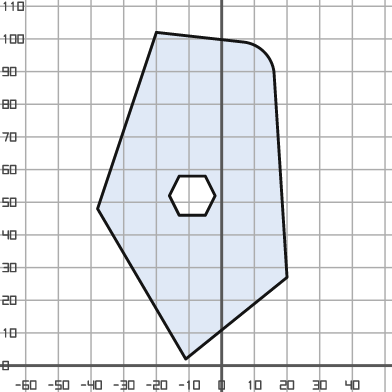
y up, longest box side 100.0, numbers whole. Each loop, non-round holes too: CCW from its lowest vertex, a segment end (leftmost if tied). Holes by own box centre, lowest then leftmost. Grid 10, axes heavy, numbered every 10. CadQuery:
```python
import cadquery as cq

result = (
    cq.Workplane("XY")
    .moveTo(-11.0, 2.0)
    .lineTo(20.0, 27.0)
    .lineTo(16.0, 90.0)
    .threePointArc((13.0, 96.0), (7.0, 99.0))
    .lineTo(-20.0, 102.0)
    .lineTo(-38.0, 48.0)
    .close()
    .moveTo(-13.0, 46.0)
    .lineTo(-5.0, 46.0)
    .lineTo(-2.0, 52.0)
    .lineTo(-5.0, 58.0)
    .lineTo(-13.0, 58.0)
    .lineTo(-16.0, 52.0)
    .close()
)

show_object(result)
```